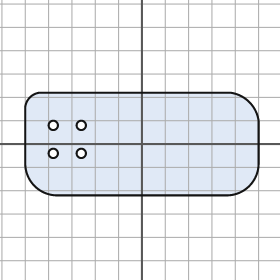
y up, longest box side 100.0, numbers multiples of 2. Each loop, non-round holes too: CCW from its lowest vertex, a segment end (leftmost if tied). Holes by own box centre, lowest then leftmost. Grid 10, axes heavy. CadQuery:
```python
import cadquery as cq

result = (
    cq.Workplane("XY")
    .moveTo(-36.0, -22.0)
    .lineTo(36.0, -22.0)
    .threePointArc((46.0, -18.0), (50.0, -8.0))
    .lineTo(50.0, 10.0)
    .threePointArc((46.0, 18.0), (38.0, 22.0))
    .lineTo(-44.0, 22.0)
    .threePointArc((-48.0, 20.0), (-50.0, 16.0))
    .lineTo(-50.0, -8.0)
    .threePointArc((-46.0, -18.0), (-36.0, -22.0))
    .close()
    .moveTo(-38.0, -4.0)
    .circle(2.0)
    .moveTo(-26.0, -4.0)
    .circle(2.0)
    .moveTo(-38.0, 8.0)
    .circle(2.0)
    .moveTo(-26.0, 8.0)
    .circle(2.0)
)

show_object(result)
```